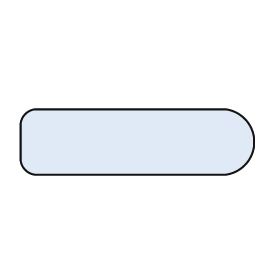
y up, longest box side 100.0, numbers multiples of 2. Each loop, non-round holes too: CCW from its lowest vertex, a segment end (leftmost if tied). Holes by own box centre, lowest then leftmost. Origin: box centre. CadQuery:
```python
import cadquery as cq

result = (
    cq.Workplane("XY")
    .moveTo(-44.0, -14.0)
    .lineTo(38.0, -14.0)
    .threePointArc((46.0, -10.0), (50.0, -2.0))
    .lineTo(50.0, 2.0)
    .threePointArc((46.0, 10.0), (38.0, 14.0))
    .lineTo(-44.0, 14.0)
    .threePointArc((-48.0, 12.0), (-50.0, 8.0))
    .lineTo(-50.0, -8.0)
    .threePointArc((-48.0, -12.0), (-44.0, -14.0))
    .close()
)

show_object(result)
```